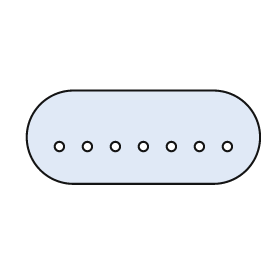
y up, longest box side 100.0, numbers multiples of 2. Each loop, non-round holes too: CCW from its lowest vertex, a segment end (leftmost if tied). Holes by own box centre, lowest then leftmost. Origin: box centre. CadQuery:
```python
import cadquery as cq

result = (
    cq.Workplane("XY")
    .moveTo(-30.0, -20.0)
    .lineTo(30.0, -20.0)
    .threePointArc((50.0, 0.0), (30.0, 20.0))
    .lineTo(-30.0, 20.0)
    .threePointArc((-50.0, 0.0), (-30.0, -20.0))
    .close()
    .moveTo(-36.0, -4.0)
    .circle(2.0)
    .moveTo(-24.0, -4.0)
    .circle(2.0)
    .moveTo(-12.0, -4.0)
    .circle(2.0)
    .moveTo(0.0, -4.0)
    .circle(2.0)
    .moveTo(12.0, -4.0)
    .circle(2.0)
    .moveTo(24.0, -4.0)
    .circle(2.0)
    .moveTo(36.0, -4.0)
    .circle(2.0)
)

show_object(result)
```